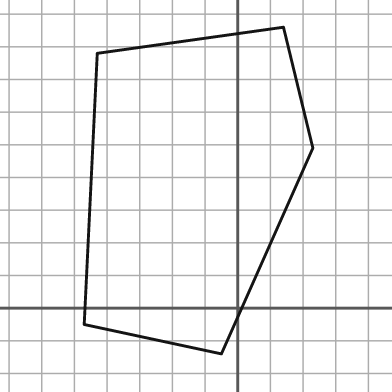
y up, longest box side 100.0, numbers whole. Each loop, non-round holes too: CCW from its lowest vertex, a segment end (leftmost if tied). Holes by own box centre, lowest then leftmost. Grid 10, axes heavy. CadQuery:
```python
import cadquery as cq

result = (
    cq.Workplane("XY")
    .moveTo(-5.0, -14.0)
    .lineTo(23.0, 49.0)
    .lineTo(14.0, 86.0)
    .lineTo(-43.0, 78.0)
    .lineTo(-47.0, -5.0)
    .close()
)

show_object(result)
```